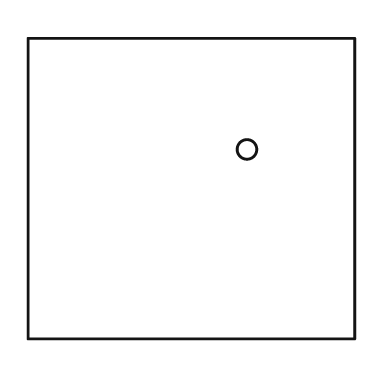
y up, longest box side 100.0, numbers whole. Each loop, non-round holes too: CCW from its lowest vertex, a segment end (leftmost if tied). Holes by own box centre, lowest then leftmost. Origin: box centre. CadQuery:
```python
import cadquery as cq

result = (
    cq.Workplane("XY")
    .moveTo(-50.0, -46.0)
    .lineTo(50.0, -46.0)
    .lineTo(50.0, 46.0)
    .lineTo(-50.0, 46.0)
    .close()
    .moveTo(17.0, 12.0)
    .circle(3.0)
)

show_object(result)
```